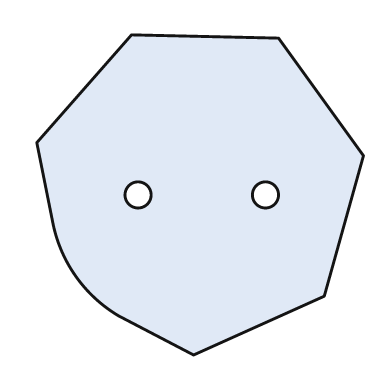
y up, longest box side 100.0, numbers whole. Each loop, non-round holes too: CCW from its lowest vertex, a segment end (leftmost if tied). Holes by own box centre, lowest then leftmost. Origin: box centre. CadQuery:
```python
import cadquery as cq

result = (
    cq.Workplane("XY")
    .moveTo(-2.0, -49.0)
    .lineTo(38.0, -31.0)
    .lineTo(50.0, 12.0)
    .lineTo(24.0, 48.0)
    .lineTo(-21.0, 49.0)
    .lineTo(-50.0, 16.0)
    .lineTo(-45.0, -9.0)
    .threePointArc((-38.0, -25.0), (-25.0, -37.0))
    .close()
    .moveTo(-19.0, 0.0)
    .circle(4.0)
    .moveTo(20.0, 0.0)
    .circle(4.0)
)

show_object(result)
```